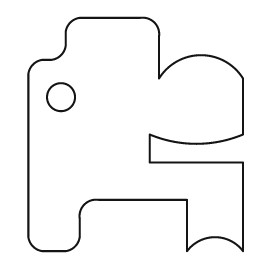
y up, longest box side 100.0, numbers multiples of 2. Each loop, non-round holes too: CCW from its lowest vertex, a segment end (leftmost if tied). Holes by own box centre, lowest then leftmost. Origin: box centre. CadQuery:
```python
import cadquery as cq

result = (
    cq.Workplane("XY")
    .moveTo(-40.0, -50.0)
    .lineTo(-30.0, -50.0)
    .threePointArc((-26.0, -48.0), (-24.0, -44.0))
    .lineTo(-24.0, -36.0)
    .threePointArc((-22.0, -30.0), (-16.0, -28.0))
    .lineTo(22.0, -28.0)
    .lineTo(22.0, -50.0)
    .threePointArc((34.0, -44.0), (46.0, -50.0))
    .lineTo(46.0, -12.0)
    .lineTo(6.0, -12.0)
    .lineTo(6.0, 0.0)
    .threePointArc((26.0, -4.0), (46.0, 0.0))
    .lineTo(46.0, 24.0)
    .threePointArc((28.0, 34.0), (10.0, 24.0))
    .lineTo(10.0, 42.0)
    .threePointArc((8.0, 48.0), (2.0, 50.0))
    .lineTo(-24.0, 50.0)
    .threePointArc((-28.0, 48.0), (-30.0, 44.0))
    .lineTo(-30.0, 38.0)
    .threePointArc((-32.0, 34.0), (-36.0, 32.0))
    .lineTo(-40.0, 32.0)
    .threePointArc((-44.0, 30.0), (-46.0, 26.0))
    .lineTo(-46.0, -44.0)
    .threePointArc((-44.0, -48.0), (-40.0, -50.0))
    .close()
    .moveTo(-32.0, 16.0)
    .circle(6.0)
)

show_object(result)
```